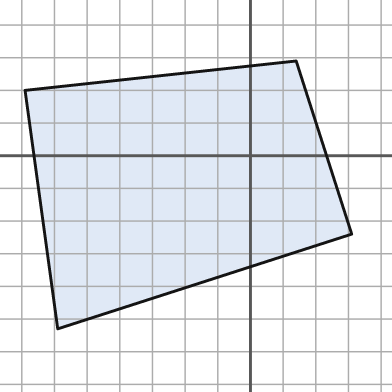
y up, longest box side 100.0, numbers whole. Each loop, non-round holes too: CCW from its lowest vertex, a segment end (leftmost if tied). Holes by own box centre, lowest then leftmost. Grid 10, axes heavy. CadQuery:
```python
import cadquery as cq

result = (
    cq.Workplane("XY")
    .moveTo(-59.0, -53.0)
    .lineTo(31.0, -24.0)
    .lineTo(14.0, 29.0)
    .lineTo(-69.0, 20.0)
    .close()
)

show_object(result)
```